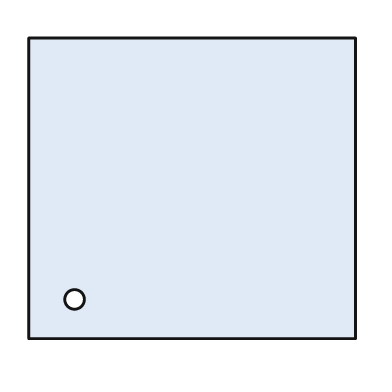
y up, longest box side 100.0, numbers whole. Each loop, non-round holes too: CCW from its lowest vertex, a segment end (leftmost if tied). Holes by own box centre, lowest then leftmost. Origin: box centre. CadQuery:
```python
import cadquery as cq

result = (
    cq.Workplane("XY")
    .moveTo(-50.0, -46.0)
    .lineTo(50.0, -46.0)
    .lineTo(50.0, 46.0)
    .lineTo(-50.0, 46.0)
    .close()
    .moveTo(-36.0, -34.0)
    .circle(3.0)
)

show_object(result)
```